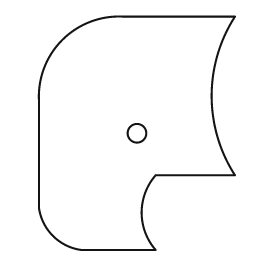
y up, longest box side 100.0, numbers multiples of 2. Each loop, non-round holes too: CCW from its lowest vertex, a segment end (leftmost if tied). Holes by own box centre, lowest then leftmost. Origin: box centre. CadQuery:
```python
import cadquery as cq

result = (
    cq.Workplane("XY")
    .moveTo(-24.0, -50.0)
    .lineTo(8.0, -50.0)
    .threePointArc((2.0, -34.0), (8.0, -18.0))
    .lineTo(42.0, -18.0)
    .threePointArc((32.0, 16.0), (42.0, 50.0))
    .lineTo(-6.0, 50.0)
    .threePointArc((-32.0, 40.0), (-42.0, 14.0))
    .lineTo(-42.0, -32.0)
    .threePointArc((-36.0, -44.0), (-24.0, -50.0))
    .close()
    .moveTo(0.0, 0.0)
    .circle(4.0)
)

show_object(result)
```